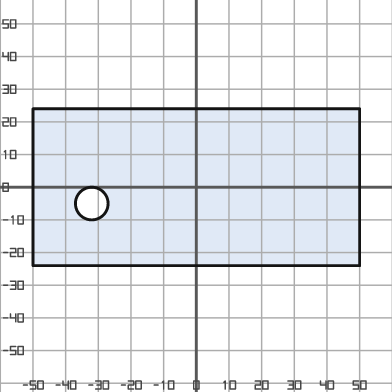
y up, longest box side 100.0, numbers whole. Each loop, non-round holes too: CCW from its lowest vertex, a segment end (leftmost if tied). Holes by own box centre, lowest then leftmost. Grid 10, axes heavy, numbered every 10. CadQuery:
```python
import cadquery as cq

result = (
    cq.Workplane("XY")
    .moveTo(-50.0, -24.0)
    .lineTo(50.0, -24.0)
    .lineTo(50.0, 24.0)
    .lineTo(-50.0, 24.0)
    .close()
    .moveTo(-32.0, -5.0)
    .circle(5.0)
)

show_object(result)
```